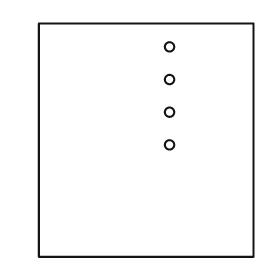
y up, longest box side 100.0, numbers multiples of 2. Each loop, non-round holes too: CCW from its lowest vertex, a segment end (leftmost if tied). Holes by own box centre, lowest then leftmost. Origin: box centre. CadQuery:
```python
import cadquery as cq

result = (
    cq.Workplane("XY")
    .moveTo(-46.0, -50.0)
    .lineTo(46.0, -50.0)
    .lineTo(46.0, 50.0)
    .lineTo(-46.0, 50.0)
    .close()
    .moveTo(10.0, -2.0)
    .circle(2.0)
    .moveTo(10.0, 12.0)
    .circle(2.0)
    .moveTo(10.0, 26.0)
    .circle(2.0)
    .moveTo(10.0, 40.0)
    .circle(2.0)
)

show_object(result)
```